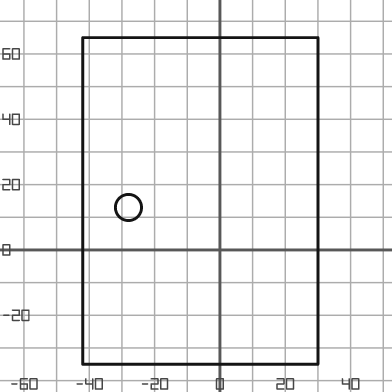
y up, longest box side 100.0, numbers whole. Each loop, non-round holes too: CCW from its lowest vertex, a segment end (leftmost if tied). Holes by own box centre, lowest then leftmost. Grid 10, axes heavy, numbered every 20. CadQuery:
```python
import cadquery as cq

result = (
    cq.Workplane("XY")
    .moveTo(-42.0, -35.0)
    .lineTo(30.0, -35.0)
    .lineTo(30.0, 65.0)
    .lineTo(-42.0, 65.0)
    .close()
    .moveTo(-28.0, 13.0)
    .circle(4.0)
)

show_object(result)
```